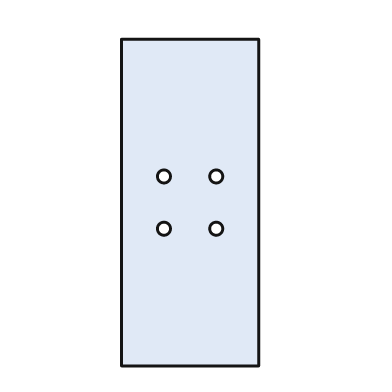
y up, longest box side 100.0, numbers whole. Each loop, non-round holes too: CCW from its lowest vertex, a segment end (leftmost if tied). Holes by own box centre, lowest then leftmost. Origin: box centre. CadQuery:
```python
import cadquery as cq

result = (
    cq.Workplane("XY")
    .moveTo(-21.0, -50.0)
    .lineTo(21.0, -50.0)
    .lineTo(21.0, 50.0)
    .lineTo(-21.0, 50.0)
    .close()
    .moveTo(-8.0, -8.0)
    .circle(2.0)
    .moveTo(8.0, -8.0)
    .circle(2.0)
    .moveTo(-8.0, 8.0)
    .circle(2.0)
    .moveTo(8.0, 8.0)
    .circle(2.0)
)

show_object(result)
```